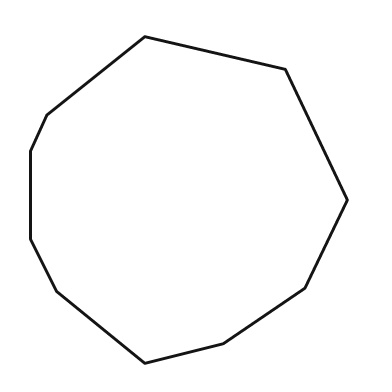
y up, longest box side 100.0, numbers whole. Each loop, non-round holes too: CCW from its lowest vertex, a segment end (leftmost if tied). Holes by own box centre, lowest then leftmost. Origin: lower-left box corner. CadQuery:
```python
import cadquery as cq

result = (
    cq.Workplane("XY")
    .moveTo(35.0, 0.0)
    .lineTo(59.0, 6.0)
    .lineTo(84.0, 23.0)
    .lineTo(97.0, 50.0)
    .lineTo(78.0, 90.0)
    .lineTo(35.0, 100.0)
    .lineTo(5.0, 76.0)
    .lineTo(0.0, 65.0)
    .lineTo(0.0, 38.0)
    .lineTo(8.0, 22.0)
    .close()
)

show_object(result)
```